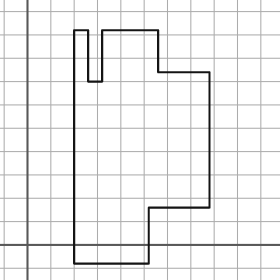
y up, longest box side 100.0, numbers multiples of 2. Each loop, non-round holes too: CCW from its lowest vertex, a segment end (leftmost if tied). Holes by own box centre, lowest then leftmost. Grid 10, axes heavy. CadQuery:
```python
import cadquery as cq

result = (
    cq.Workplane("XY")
    .moveTo(20.0, -8.0)
    .lineTo(52.0, -8.0)
    .lineTo(52.0, 16.0)
    .lineTo(78.0, 16.0)
    .lineTo(78.0, 74.0)
    .lineTo(56.0, 74.0)
    .lineTo(56.0, 92.0)
    .lineTo(32.0, 92.0)
    .lineTo(32.0, 70.0)
    .lineTo(26.0, 70.0)
    .lineTo(26.0, 92.0)
    .lineTo(20.0, 92.0)
    .close()
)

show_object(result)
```